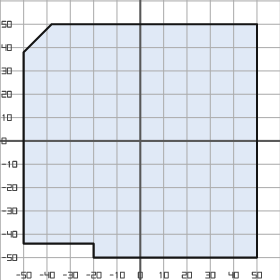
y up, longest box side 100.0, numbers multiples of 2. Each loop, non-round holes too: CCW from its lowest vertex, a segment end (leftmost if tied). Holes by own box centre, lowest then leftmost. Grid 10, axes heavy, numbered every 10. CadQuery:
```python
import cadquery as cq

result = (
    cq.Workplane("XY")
    .moveTo(-20.0, -50.0)
    .lineTo(50.0, -50.0)
    .lineTo(50.0, 50.0)
    .lineTo(-38.0, 50.0)
    .lineTo(-50.0, 38.0)
    .lineTo(-50.0, -44.0)
    .lineTo(-20.0, -44.0)
    .close()
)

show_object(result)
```